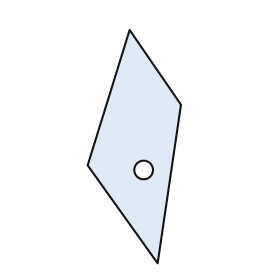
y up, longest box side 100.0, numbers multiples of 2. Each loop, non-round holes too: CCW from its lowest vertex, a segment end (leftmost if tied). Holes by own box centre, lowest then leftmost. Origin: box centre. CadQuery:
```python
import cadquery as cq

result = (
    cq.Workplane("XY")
    .moveTo(10.0, -50.0)
    .lineTo(20.0, 18.0)
    .lineTo(-2.0, 50.0)
    .lineTo(-20.0, -8.0)
    .close()
    .moveTo(4.0, -10.0)
    .circle(4.0)
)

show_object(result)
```